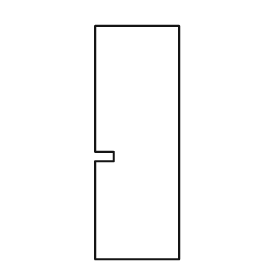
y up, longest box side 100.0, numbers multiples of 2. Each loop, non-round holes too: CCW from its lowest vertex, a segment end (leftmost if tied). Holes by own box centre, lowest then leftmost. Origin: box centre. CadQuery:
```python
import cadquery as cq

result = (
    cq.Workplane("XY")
    .moveTo(-18.0, -50.0)
    .lineTo(18.0, -50.0)
    .lineTo(18.0, 50.0)
    .lineTo(-18.0, 50.0)
    .lineTo(-18.0, -4.0)
    .lineTo(-10.0, -4.0)
    .lineTo(-10.0, -8.0)
    .lineTo(-18.0, -8.0)
    .close()
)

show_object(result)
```